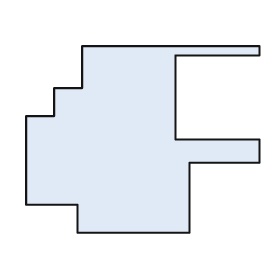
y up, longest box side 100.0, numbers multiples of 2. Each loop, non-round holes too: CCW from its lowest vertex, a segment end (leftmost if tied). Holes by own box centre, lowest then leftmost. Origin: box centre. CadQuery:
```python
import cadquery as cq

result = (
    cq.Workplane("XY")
    .moveTo(-28.0, -40.0)
    .lineTo(20.0, -40.0)
    .lineTo(20.0, -10.0)
    .lineTo(50.0, -10.0)
    .lineTo(50.0, 0.0)
    .lineTo(14.0, 0.0)
    .lineTo(14.0, 36.0)
    .lineTo(50.0, 36.0)
    .lineTo(50.0, 40.0)
    .lineTo(-26.0, 40.0)
    .lineTo(-26.0, 22.0)
    .lineTo(-38.0, 22.0)
    .lineTo(-38.0, 10.0)
    .lineTo(-50.0, 10.0)
    .lineTo(-50.0, -28.0)
    .lineTo(-28.0, -28.0)
    .close()
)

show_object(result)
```